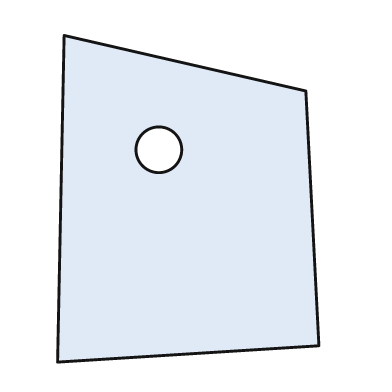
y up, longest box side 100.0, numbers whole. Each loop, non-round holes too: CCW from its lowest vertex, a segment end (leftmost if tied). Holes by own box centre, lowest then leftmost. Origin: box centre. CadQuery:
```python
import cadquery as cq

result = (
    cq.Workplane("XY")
    .moveTo(-40.0, -50.0)
    .lineTo(40.0, -45.0)
    .lineTo(36.0, 33.0)
    .lineTo(-38.0, 50.0)
    .close()
    .moveTo(-9.0, 15.0)
    .circle(7.0)
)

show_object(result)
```